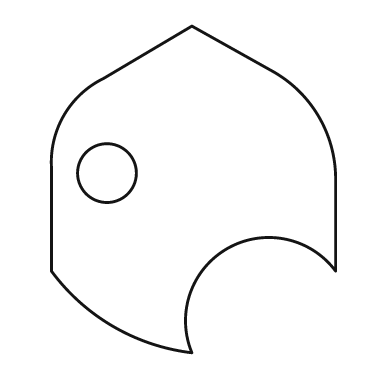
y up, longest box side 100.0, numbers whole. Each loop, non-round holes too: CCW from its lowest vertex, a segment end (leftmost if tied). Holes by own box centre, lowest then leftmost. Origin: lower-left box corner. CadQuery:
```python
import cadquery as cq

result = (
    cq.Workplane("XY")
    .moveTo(43.0, 0.0)
    .threePointArc((54.0, 32.0), (87.0, 25.0))
    .lineTo(87.0, 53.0)
    .threePointArc((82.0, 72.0), (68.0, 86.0))
    .lineTo(43.0, 100.0)
    .lineTo(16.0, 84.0)
    .threePointArc((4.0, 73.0), (0.0, 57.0))
    .lineTo(0.0, 25.0)
    .threePointArc((19.0, 8.0), (43.0, 0.0))
    .close()
    .moveTo(17.0, 55.0)
    .circle(9.0)
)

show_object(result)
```